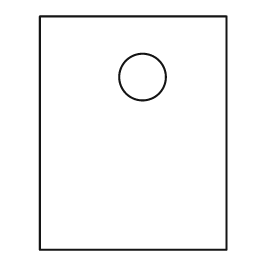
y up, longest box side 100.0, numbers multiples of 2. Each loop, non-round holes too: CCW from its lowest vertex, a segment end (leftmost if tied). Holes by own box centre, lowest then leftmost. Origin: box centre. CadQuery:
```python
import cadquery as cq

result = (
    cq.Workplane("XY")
    .moveTo(-40.0, -50.0)
    .lineTo(40.0, -50.0)
    .lineTo(40.0, 50.0)
    .lineTo(-40.0, 50.0)
    .close()
    .moveTo(4.0, 24.0)
    .circle(10.0)
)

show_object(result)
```